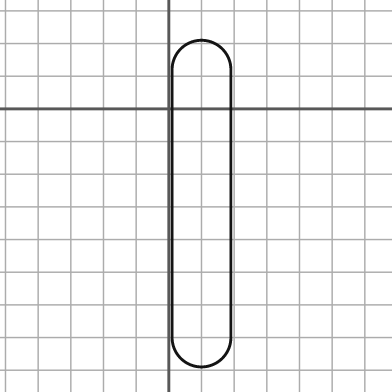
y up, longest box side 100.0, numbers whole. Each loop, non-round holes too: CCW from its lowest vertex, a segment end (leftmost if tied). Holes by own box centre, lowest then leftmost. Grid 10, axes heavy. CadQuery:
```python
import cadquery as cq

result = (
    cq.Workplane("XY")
    .moveTo(1.0, -70.0)
    .threePointArc((10.0, -79.0), (19.0, -70.0))
    .lineTo(19.0, 12.0)
    .threePointArc((10.0, 21.0), (1.0, 12.0))
    .close()
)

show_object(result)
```